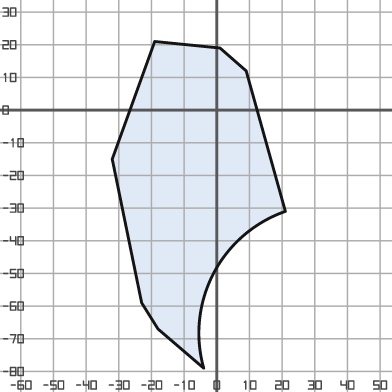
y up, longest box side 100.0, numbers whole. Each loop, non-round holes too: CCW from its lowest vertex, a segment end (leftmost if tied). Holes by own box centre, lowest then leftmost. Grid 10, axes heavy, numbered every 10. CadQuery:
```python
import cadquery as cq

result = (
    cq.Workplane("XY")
    .moveTo(-4.0, -79.0)
    .threePointArc((-1.0, -50.0), (21.0, -31.0))
    .lineTo(9.0, 12.0)
    .lineTo(1.0, 19.0)
    .lineTo(-19.0, 21.0)
    .lineTo(-32.0, -15.0)
    .lineTo(-23.0, -59.0)
    .lineTo(-18.0, -67.0)
    .close()
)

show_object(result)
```